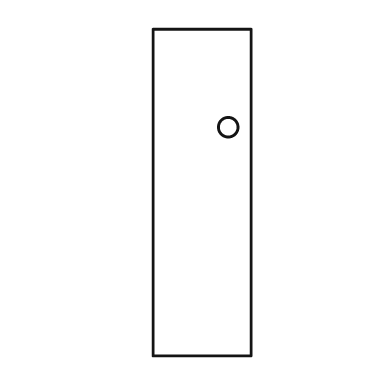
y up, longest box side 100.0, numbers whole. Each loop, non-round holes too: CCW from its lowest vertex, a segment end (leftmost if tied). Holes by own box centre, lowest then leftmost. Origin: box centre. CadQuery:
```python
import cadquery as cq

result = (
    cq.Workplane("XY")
    .moveTo(-15.0, -50.0)
    .lineTo(15.0, -50.0)
    .lineTo(15.0, 50.0)
    .lineTo(-15.0, 50.0)
    .close()
    .moveTo(8.0, 20.0)
    .circle(3.0)
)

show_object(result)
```